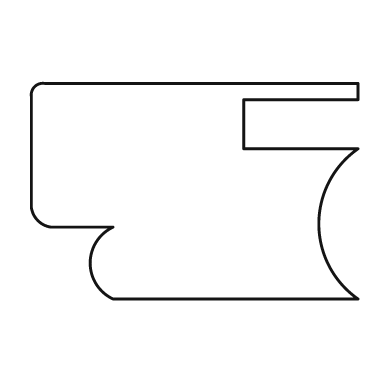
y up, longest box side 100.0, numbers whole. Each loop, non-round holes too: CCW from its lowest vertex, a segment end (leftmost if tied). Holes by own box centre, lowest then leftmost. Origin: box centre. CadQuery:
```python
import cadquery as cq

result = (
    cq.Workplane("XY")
    .moveTo(-25.0, -33.0)
    .lineTo(50.0, -33.0)
    .threePointArc((38.0, -10.0), (50.0, 13.0))
    .lineTo(15.0, 13.0)
    .lineTo(15.0, 28.0)
    .lineTo(50.0, 28.0)
    .lineTo(50.0, 33.0)
    .lineTo(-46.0, 33.0)
    .threePointArc((-49.0, 32.0), (-50.0, 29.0))
    .lineTo(-50.0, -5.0)
    .threePointArc((-48.0, -9.0), (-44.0, -11.0))
    .lineTo(-25.0, -11.0)
    .threePointArc((-32.0, -22.0), (-25.0, -33.0))
    .close()
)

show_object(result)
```